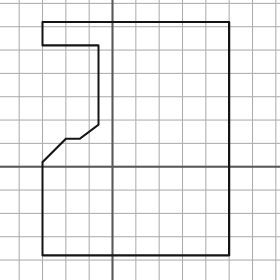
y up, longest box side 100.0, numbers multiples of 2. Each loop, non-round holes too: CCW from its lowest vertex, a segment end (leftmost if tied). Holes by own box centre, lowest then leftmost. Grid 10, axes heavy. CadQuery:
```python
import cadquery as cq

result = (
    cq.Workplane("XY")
    .moveTo(-30.0, -38.0)
    .lineTo(50.0, -38.0)
    .lineTo(50.0, 62.0)
    .lineTo(-30.0, 62.0)
    .lineTo(-30.0, 52.0)
    .lineTo(-6.0, 52.0)
    .lineTo(-6.0, 18.0)
    .lineTo(-14.0, 12.0)
    .lineTo(-20.0, 12.0)
    .lineTo(-30.0, 2.0)
    .close()
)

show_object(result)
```